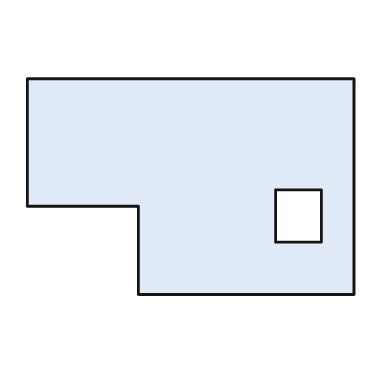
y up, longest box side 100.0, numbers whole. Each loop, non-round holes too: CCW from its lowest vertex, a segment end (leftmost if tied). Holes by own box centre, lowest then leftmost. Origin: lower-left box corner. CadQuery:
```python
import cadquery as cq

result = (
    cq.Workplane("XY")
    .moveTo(34.0, 0.0)
    .lineTo(100.0, 0.0)
    .lineTo(100.0, 66.0)
    .lineTo(0.0, 66.0)
    .lineTo(0.0, 27.0)
    .lineTo(34.0, 27.0)
    .close()
    .moveTo(76.0, 16.0)
    .lineTo(90.0, 16.0)
    .lineTo(90.0, 32.0)
    .lineTo(76.0, 32.0)
    .close()
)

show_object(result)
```